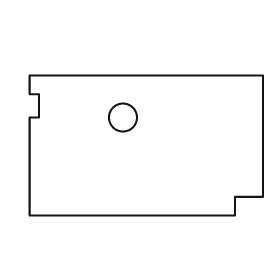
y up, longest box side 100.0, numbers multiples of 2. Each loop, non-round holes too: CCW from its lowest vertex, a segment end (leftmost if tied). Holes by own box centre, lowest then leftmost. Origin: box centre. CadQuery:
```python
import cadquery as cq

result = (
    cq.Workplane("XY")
    .moveTo(-50.0, -30.0)
    .lineTo(38.0, -30.0)
    .lineTo(38.0, -22.0)
    .lineTo(50.0, -22.0)
    .lineTo(50.0, 30.0)
    .lineTo(-50.0, 30.0)
    .lineTo(-50.0, 22.0)
    .lineTo(-46.0, 22.0)
    .lineTo(-46.0, 12.0)
    .lineTo(-50.0, 12.0)
    .close()
    .moveTo(-10.0, 12.0)
    .circle(6.0)
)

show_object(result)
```